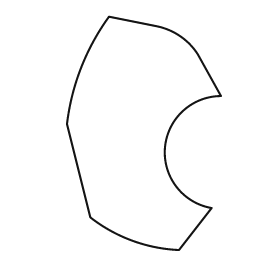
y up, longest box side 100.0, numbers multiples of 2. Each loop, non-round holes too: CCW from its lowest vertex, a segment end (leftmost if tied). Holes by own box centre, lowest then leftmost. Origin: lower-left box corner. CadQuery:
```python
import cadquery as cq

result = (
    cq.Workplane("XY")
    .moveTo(48.0, 0.0)
    .lineTo(62.0, 18.0)
    .threePointArc((42.0, 44.0), (66.0, 66.0))
    .lineTo(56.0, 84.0)
    .threePointArc((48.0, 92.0), (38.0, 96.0))
    .lineTo(18.0, 100.0)
    .threePointArc((6.0, 78.0), (0.0, 54.0))
    .lineTo(10.0, 14.0)
    .threePointArc((28.0, 4.0), (48.0, 0.0))
    .close()
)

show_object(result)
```